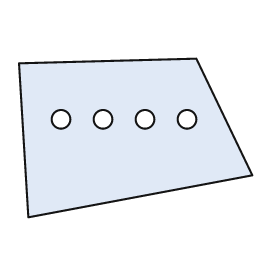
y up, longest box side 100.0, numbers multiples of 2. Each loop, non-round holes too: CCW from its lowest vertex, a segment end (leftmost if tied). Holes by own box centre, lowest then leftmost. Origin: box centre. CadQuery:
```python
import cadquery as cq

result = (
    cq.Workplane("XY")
    .moveTo(-46.0, -34.0)
    .lineTo(50.0, -16.0)
    .lineTo(26.0, 34.0)
    .lineTo(-50.0, 32.0)
    .close()
    .moveTo(-32.0, 8.0)
    .circle(4.0)
    .moveTo(-14.0, 8.0)
    .circle(4.0)
    .moveTo(4.0, 8.0)
    .circle(4.0)
    .moveTo(22.0, 8.0)
    .circle(4.0)
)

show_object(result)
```